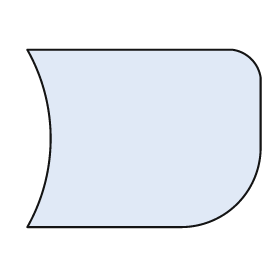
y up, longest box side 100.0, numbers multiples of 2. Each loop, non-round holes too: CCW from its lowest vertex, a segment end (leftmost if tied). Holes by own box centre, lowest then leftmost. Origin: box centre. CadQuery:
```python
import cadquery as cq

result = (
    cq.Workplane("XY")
    .moveTo(-50.0, -38.0)
    .lineTo(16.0, -38.0)
    .threePointArc((40.0, -28.0), (50.0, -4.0))
    .lineTo(50.0, 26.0)
    .threePointArc((46.0, 34.0), (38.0, 38.0))
    .lineTo(-50.0, 38.0)
    .threePointArc((-40.0, 0.0), (-50.0, -38.0))
    .close()
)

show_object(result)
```